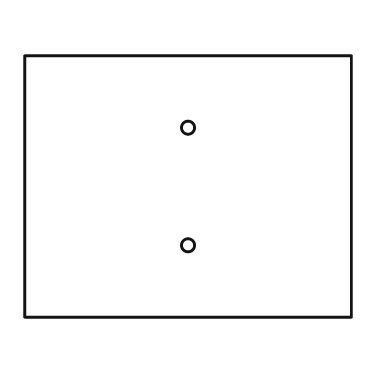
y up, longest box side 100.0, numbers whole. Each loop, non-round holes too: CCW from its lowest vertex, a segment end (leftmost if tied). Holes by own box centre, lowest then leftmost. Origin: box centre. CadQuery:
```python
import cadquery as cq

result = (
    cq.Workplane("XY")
    .moveTo(-50.0, -40.0)
    .lineTo(50.0, -40.0)
    .lineTo(50.0, 40.0)
    .lineTo(-50.0, 40.0)
    .close()
    .moveTo(0.0, -18.0)
    .circle(2.0)
    .moveTo(0.0, 18.0)
    .circle(2.0)
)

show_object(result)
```